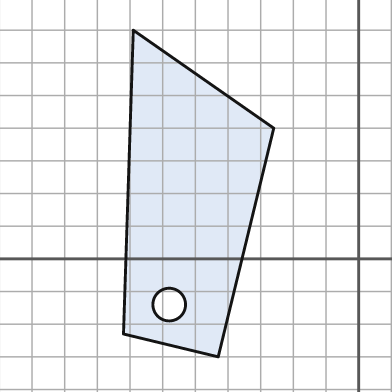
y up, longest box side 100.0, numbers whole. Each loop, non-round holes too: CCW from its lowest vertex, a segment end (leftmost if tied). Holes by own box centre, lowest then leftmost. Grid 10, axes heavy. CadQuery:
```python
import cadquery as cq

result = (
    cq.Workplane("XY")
    .moveTo(-43.0, -30.0)
    .lineTo(-26.0, 40.0)
    .lineTo(-69.0, 70.0)
    .lineTo(-72.0, -23.0)
    .close()
    .moveTo(-58.0, -14.0)
    .circle(5.0)
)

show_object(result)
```